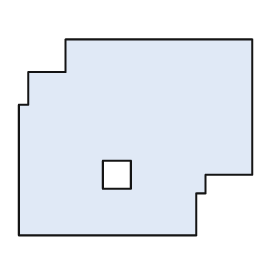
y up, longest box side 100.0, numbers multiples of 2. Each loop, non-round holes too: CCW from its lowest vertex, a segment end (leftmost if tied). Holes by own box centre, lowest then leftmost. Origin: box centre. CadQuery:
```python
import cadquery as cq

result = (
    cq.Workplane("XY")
    .moveTo(-50.0, -42.0)
    .lineTo(26.0, -42.0)
    .lineTo(26.0, -24.0)
    .lineTo(30.0, -24.0)
    .lineTo(30.0, -16.0)
    .lineTo(50.0, -16.0)
    .lineTo(50.0, 42.0)
    .lineTo(-30.0, 42.0)
    .lineTo(-30.0, 28.0)
    .lineTo(-46.0, 28.0)
    .lineTo(-46.0, 14.0)
    .lineTo(-50.0, 14.0)
    .close()
    .moveTo(-14.0, -22.0)
    .lineTo(-2.0, -22.0)
    .lineTo(-2.0, -10.0)
    .lineTo(-14.0, -10.0)
    .close()
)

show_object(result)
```